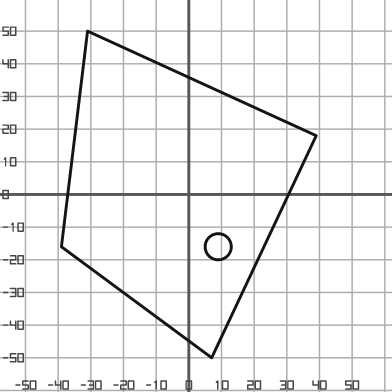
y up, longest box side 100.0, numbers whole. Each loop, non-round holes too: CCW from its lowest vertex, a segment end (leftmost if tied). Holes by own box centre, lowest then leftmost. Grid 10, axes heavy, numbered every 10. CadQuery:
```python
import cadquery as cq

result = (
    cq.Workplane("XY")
    .moveTo(7.0, -50.0)
    .lineTo(39.0, 18.0)
    .lineTo(-31.0, 50.0)
    .lineTo(-39.0, -16.0)
    .close()
    .moveTo(9.0, -16.0)
    .circle(4.0)
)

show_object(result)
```